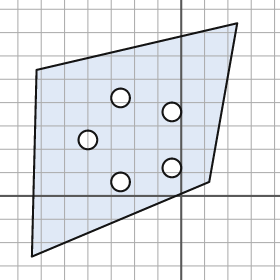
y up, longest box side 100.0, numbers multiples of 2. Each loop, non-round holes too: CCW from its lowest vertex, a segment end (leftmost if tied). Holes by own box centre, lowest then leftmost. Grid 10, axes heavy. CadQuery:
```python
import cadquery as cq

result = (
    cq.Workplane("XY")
    .moveTo(-64.0, -26.0)
    .lineTo(12.0, 6.0)
    .lineTo(24.0, 74.0)
    .lineTo(-62.0, 54.0)
    .close()
    .moveTo(-26.0, 6.0)
    .circle(4.0)
    .moveTo(-4.0, 12.0)
    .circle(4.0)
    .moveTo(-40.0, 24.0)
    .circle(4.0)
    .moveTo(-4.0, 36.0)
    .circle(4.0)
    .moveTo(-26.0, 42.0)
    .circle(4.0)
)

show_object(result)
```